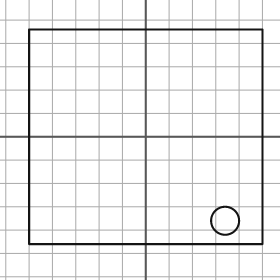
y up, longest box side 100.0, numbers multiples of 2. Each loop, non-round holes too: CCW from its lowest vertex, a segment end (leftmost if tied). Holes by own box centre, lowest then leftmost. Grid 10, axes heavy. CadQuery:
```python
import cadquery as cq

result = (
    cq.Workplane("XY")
    .moveTo(-50.0, -46.0)
    .lineTo(50.0, -46.0)
    .lineTo(50.0, 46.0)
    .lineTo(-50.0, 46.0)
    .close()
    .moveTo(34.0, -36.0)
    .circle(6.0)
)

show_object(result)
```